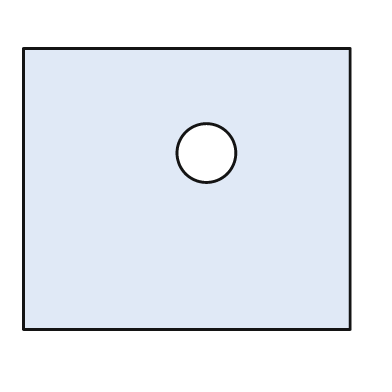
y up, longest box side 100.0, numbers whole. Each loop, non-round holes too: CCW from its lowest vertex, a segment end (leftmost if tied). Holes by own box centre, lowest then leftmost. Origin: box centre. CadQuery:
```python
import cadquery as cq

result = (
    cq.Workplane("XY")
    .moveTo(-50.0, -43.0)
    .lineTo(50.0, -43.0)
    .lineTo(50.0, 43.0)
    .lineTo(-50.0, 43.0)
    .close()
    .moveTo(6.0, 11.0)
    .circle(9.0)
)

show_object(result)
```